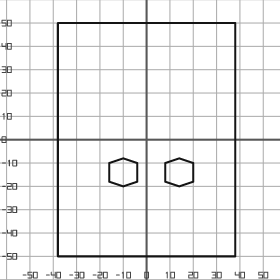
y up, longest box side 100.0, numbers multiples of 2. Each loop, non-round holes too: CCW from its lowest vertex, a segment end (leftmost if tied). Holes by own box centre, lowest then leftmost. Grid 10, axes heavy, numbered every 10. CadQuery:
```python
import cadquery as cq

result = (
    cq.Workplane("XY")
    .moveTo(-38.0, -50.0)
    .lineTo(38.0, -50.0)
    .lineTo(38.0, 50.0)
    .lineTo(-38.0, 50.0)
    .close()
    .moveTo(-10.0, -20.0)
    .lineTo(-4.0, -18.0)
    .lineTo(-4.0, -10.0)
    .lineTo(-10.0, -8.0)
    .lineTo(-16.0, -10.0)
    .lineTo(-16.0, -18.0)
    .close()
    .moveTo(14.0, -20.0)
    .lineTo(20.0, -18.0)
    .lineTo(20.0, -10.0)
    .lineTo(14.0, -8.0)
    .lineTo(8.0, -10.0)
    .lineTo(8.0, -18.0)
    .close()
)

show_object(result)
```